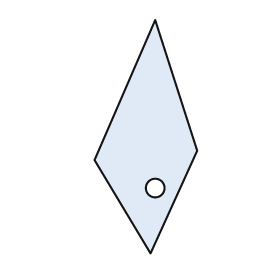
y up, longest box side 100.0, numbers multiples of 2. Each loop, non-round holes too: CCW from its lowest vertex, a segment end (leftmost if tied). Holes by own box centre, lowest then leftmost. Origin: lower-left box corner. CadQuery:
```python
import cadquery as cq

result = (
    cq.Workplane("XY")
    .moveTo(24.0, 0.0)
    .lineTo(44.0, 44.0)
    .lineTo(26.0, 100.0)
    .lineTo(0.0, 40.0)
    .close()
    .moveTo(26.0, 28.0)
    .circle(4.0)
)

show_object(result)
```